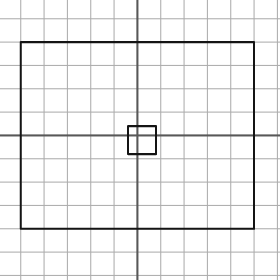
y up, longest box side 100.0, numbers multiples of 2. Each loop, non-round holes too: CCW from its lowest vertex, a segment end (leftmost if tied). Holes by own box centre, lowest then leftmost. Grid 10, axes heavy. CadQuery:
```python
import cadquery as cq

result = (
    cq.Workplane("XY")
    .moveTo(-50.0, -40.0)
    .lineTo(50.0, -40.0)
    .lineTo(50.0, 40.0)
    .lineTo(-50.0, 40.0)
    .close()
    .moveTo(-4.0, -8.0)
    .lineTo(8.0, -8.0)
    .lineTo(8.0, 4.0)
    .lineTo(-4.0, 4.0)
    .close()
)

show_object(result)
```